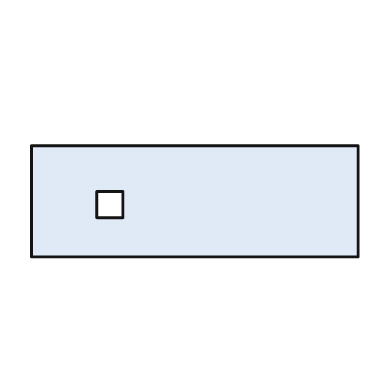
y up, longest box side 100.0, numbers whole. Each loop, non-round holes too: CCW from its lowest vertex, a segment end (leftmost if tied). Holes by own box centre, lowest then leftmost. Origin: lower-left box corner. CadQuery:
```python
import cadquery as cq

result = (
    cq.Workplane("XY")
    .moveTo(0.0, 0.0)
    .lineTo(100.0, 0.0)
    .lineTo(100.0, 34.0)
    .lineTo(0.0, 34.0)
    .close()
    .moveTo(20.0, 12.0)
    .lineTo(28.0, 12.0)
    .lineTo(28.0, 20.0)
    .lineTo(20.0, 20.0)
    .close()
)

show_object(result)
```